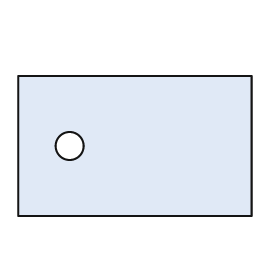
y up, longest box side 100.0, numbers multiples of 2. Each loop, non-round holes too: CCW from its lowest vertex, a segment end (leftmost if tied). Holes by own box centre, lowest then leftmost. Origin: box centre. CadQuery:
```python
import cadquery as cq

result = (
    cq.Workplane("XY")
    .moveTo(-50.0, -30.0)
    .lineTo(50.0, -30.0)
    .lineTo(50.0, 30.0)
    .lineTo(-50.0, 30.0)
    .close()
    .moveTo(-28.0, 0.0)
    .circle(6.0)
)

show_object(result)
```